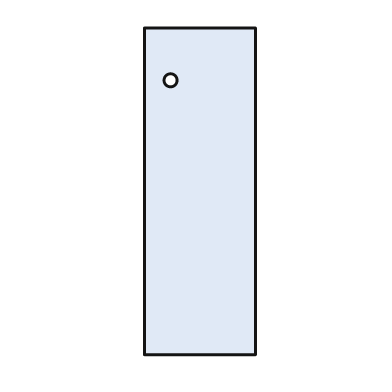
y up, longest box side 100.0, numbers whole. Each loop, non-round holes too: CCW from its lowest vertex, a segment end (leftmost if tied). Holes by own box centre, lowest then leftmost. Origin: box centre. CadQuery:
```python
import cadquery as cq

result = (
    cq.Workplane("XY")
    .moveTo(-17.0, -50.0)
    .lineTo(17.0, -50.0)
    .lineTo(17.0, 50.0)
    .lineTo(-17.0, 50.0)
    .close()
    .moveTo(-9.0, 34.0)
    .circle(2.0)
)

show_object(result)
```